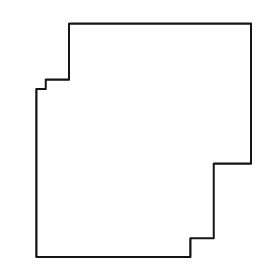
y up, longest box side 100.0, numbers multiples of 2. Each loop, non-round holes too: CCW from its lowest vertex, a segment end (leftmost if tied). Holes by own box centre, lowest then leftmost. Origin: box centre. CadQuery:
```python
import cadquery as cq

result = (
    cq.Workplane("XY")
    .moveTo(-46.0, -50.0)
    .lineTo(20.0, -50.0)
    .lineTo(20.0, -42.0)
    .lineTo(30.0, -42.0)
    .lineTo(30.0, -10.0)
    .lineTo(46.0, -10.0)
    .lineTo(46.0, 50.0)
    .lineTo(-32.0, 50.0)
    .lineTo(-32.0, 26.0)
    .lineTo(-42.0, 26.0)
    .lineTo(-42.0, 22.0)
    .lineTo(-46.0, 22.0)
    .close()
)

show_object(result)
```